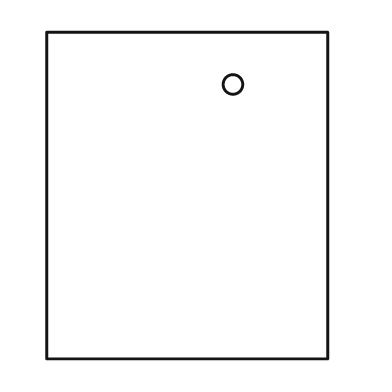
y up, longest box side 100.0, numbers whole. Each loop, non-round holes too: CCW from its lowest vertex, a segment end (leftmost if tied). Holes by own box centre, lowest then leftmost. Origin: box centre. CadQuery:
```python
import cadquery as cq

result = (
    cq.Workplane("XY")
    .moveTo(-43.0, -50.0)
    .lineTo(43.0, -50.0)
    .lineTo(43.0, 50.0)
    .lineTo(-43.0, 50.0)
    .close()
    .moveTo(14.0, 34.0)
    .circle(3.0)
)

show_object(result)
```